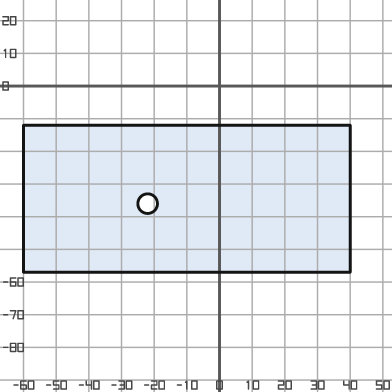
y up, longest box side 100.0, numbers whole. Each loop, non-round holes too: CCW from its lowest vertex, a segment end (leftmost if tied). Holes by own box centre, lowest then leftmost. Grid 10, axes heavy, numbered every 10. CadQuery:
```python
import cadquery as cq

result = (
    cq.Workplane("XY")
    .moveTo(-60.0, -57.0)
    .lineTo(40.0, -57.0)
    .lineTo(40.0, -12.0)
    .lineTo(-60.0, -12.0)
    .close()
    .moveTo(-22.0, -36.0)
    .circle(3.0)
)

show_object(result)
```